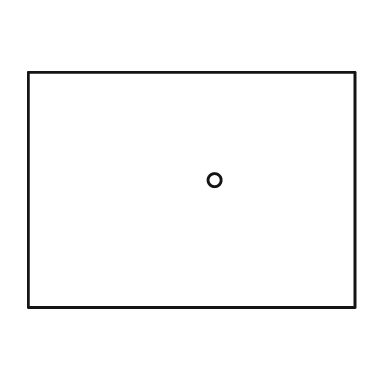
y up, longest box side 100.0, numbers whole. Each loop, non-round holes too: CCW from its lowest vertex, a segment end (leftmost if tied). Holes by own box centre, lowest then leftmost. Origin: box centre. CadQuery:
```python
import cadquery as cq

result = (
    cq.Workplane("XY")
    .moveTo(-50.0, -36.0)
    .lineTo(50.0, -36.0)
    .lineTo(50.0, 36.0)
    .lineTo(-50.0, 36.0)
    .close()
    .moveTo(7.0, 3.0)
    .circle(2.0)
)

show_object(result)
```